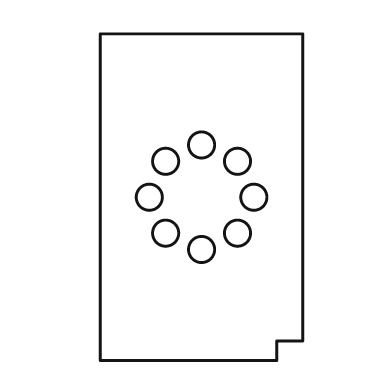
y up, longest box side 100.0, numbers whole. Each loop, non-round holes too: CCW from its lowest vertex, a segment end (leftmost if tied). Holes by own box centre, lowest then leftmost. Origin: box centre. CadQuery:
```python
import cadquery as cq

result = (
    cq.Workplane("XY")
    .moveTo(-31.0, -50.0)
    .lineTo(23.0, -50.0)
    .lineTo(23.0, -44.0)
    .lineTo(31.0, -44.0)
    .lineTo(31.0, 50.0)
    .lineTo(-31.0, 50.0)
    .close()
    .moveTo(0.0, -16.0)
    .circle(4.0)
    .moveTo(-11.0, -11.0)
    .circle(4.0)
    .moveTo(11.0, -11.0)
    .circle(4.0)
    .moveTo(-16.0, 0.0)
    .circle(4.0)
    .moveTo(16.0, 0.0)
    .circle(4.0)
    .moveTo(-11.0, 11.0)
    .circle(4.0)
    .moveTo(11.0, 11.0)
    .circle(4.0)
    .moveTo(0.0, 16.0)
    .circle(4.0)
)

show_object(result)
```